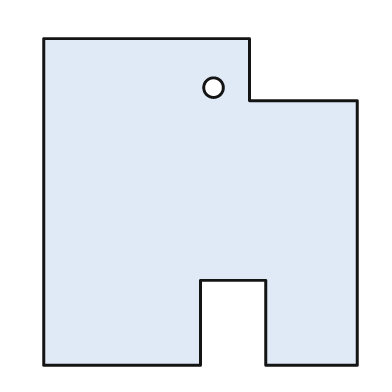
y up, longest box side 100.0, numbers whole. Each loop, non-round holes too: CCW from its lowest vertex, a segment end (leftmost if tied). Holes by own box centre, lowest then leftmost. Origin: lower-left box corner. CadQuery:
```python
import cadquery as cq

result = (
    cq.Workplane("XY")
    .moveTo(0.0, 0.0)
    .lineTo(48.0, 0.0)
    .lineTo(48.0, 26.0)
    .lineTo(68.0, 26.0)
    .lineTo(68.0, 0.0)
    .lineTo(96.0, 0.0)
    .lineTo(96.0, 81.0)
    .lineTo(63.0, 81.0)
    .lineTo(63.0, 100.0)
    .lineTo(0.0, 100.0)
    .close()
    .moveTo(52.0, 85.0)
    .circle(3.0)
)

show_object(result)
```